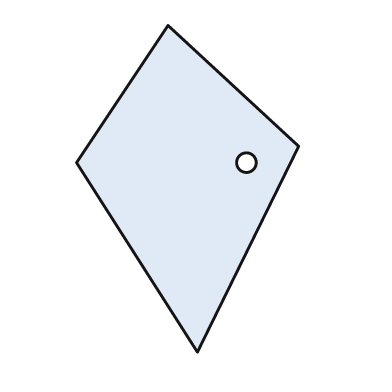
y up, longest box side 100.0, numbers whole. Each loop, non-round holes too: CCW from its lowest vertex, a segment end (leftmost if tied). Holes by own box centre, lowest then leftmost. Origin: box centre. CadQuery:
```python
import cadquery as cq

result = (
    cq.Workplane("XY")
    .moveTo(3.0, -50.0)
    .lineTo(34.0, 13.0)
    .lineTo(-6.0, 50.0)
    .lineTo(-34.0, 8.0)
    .close()
    .moveTo(18.0, 8.0)
    .circle(3.0)
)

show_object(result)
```